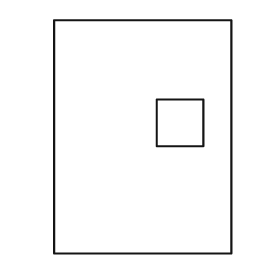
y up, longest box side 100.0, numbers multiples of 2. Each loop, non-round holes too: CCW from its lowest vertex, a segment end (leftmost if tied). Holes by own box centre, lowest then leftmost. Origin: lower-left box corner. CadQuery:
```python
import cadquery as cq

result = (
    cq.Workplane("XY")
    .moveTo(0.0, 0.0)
    .lineTo(76.0, 0.0)
    .lineTo(76.0, 100.0)
    .lineTo(0.0, 100.0)
    .close()
    .moveTo(44.0, 46.0)
    .lineTo(64.0, 46.0)
    .lineTo(64.0, 66.0)
    .lineTo(44.0, 66.0)
    .close()
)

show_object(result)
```